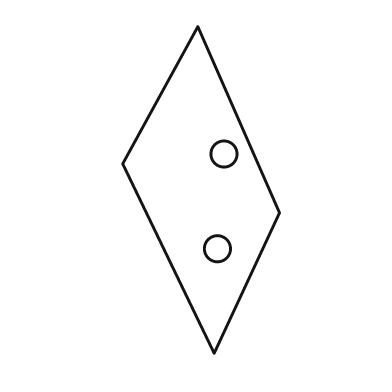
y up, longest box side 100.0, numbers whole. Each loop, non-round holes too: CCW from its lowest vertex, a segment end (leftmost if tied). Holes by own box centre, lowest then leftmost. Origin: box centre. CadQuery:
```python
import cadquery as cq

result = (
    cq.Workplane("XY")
    .moveTo(4.0, -50.0)
    .lineTo(24.0, -7.0)
    .lineTo(-1.0, 50.0)
    .lineTo(-24.0, 8.0)
    .close()
    .moveTo(5.0, -18.0)
    .circle(4.0)
    .moveTo(7.0, 11.0)
    .circle(4.0)
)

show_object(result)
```